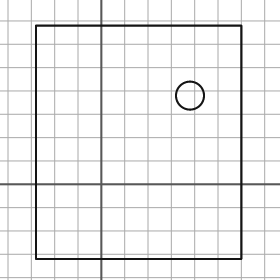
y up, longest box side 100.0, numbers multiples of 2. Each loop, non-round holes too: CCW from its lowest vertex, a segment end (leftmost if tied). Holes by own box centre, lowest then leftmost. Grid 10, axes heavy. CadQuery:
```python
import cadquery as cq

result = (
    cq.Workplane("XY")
    .moveTo(-28.0, -32.0)
    .lineTo(60.0, -32.0)
    .lineTo(60.0, 68.0)
    .lineTo(-28.0, 68.0)
    .close()
    .moveTo(38.0, 38.0)
    .circle(6.0)
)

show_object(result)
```